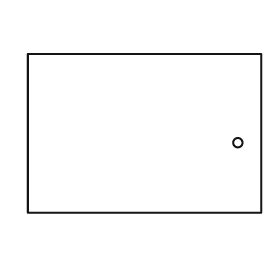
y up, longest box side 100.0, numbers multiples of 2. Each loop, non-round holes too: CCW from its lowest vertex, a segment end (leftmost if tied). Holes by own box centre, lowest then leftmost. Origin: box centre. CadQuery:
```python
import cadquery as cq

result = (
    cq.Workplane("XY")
    .moveTo(-50.0, -34.0)
    .lineTo(50.0, -34.0)
    .lineTo(50.0, 34.0)
    .lineTo(-50.0, 34.0)
    .close()
    .moveTo(40.0, -4.0)
    .circle(2.0)
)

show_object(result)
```